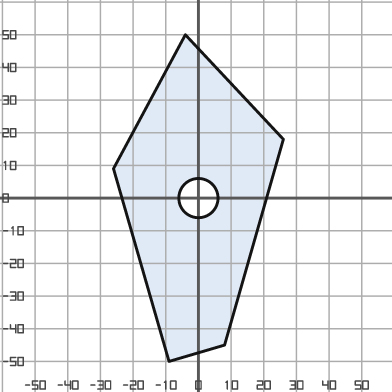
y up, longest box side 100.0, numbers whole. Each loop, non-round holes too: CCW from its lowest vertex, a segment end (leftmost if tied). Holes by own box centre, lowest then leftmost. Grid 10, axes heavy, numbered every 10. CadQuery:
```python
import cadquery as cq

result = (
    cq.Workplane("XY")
    .moveTo(-9.0, -50.0)
    .lineTo(8.0, -45.0)
    .lineTo(26.0, 18.0)
    .lineTo(-4.0, 50.0)
    .lineTo(-26.0, 9.0)
    .close()
    .moveTo(0.0, 0.0)
    .circle(6.0)
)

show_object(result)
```